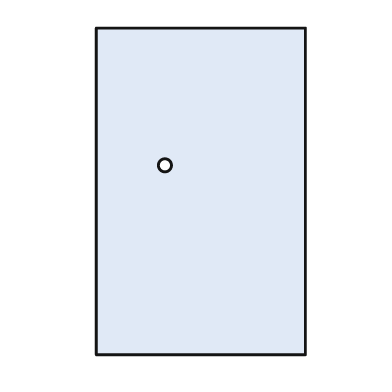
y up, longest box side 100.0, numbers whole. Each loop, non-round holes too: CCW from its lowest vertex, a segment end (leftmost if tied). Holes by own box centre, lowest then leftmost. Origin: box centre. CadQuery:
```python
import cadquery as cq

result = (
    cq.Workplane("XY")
    .moveTo(-32.0, -50.0)
    .lineTo(32.0, -50.0)
    .lineTo(32.0, 50.0)
    .lineTo(-32.0, 50.0)
    .close()
    .moveTo(-11.0, 8.0)
    .circle(2.0)
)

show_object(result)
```